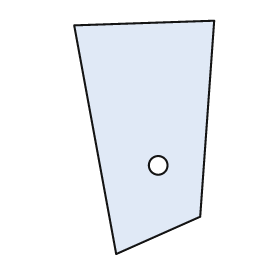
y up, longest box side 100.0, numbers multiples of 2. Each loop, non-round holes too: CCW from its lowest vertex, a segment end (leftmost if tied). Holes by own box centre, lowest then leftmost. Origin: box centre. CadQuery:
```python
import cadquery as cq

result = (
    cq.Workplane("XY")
    .moveTo(-12.0, -50.0)
    .lineTo(24.0, -34.0)
    .lineTo(30.0, 50.0)
    .lineTo(-30.0, 48.0)
    .close()
    .moveTo(6.0, -12.0)
    .circle(4.0)
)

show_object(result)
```